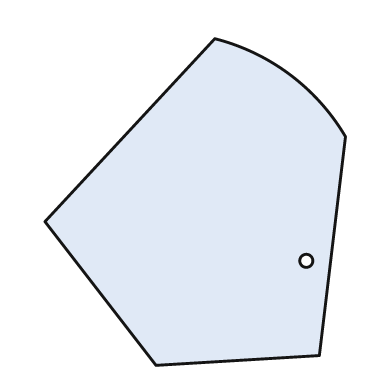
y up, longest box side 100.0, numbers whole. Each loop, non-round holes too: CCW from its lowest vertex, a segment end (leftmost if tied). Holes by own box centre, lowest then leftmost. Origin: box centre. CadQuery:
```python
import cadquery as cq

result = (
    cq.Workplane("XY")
    .moveTo(-12.0, -50.0)
    .lineTo(38.0, -47.0)
    .lineTo(46.0, 20.0)
    .threePointArc((29.0, 39.0), (6.0, 50.0))
    .lineTo(-46.0, -6.0)
    .close()
    .moveTo(34.0, -18.0)
    .circle(2.0)
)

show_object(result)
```